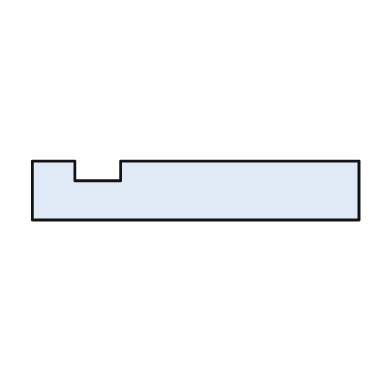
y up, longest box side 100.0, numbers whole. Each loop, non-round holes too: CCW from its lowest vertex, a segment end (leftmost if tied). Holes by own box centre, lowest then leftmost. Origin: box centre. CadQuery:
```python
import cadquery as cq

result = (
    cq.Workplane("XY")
    .moveTo(-50.0, -9.0)
    .lineTo(50.0, -9.0)
    .lineTo(50.0, 9.0)
    .lineTo(-23.0, 9.0)
    .lineTo(-23.0, 3.0)
    .lineTo(-37.0, 3.0)
    .lineTo(-37.0, 9.0)
    .lineTo(-50.0, 9.0)
    .close()
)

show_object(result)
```